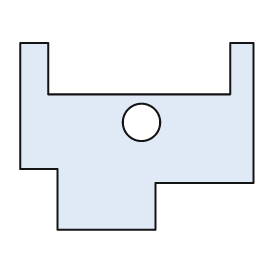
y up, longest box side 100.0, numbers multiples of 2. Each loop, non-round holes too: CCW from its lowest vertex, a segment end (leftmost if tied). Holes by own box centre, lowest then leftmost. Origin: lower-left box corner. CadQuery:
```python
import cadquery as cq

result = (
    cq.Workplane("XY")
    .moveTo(16.0, 0.0)
    .lineTo(58.0, 0.0)
    .lineTo(58.0, 20.0)
    .lineTo(100.0, 20.0)
    .lineTo(100.0, 80.0)
    .lineTo(90.0, 80.0)
    .lineTo(90.0, 58.0)
    .lineTo(12.0, 58.0)
    .lineTo(12.0, 80.0)
    .lineTo(0.0, 80.0)
    .lineTo(0.0, 26.0)
    .lineTo(16.0, 26.0)
    .close()
    .moveTo(52.0, 46.0)
    .circle(8.0)
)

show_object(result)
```